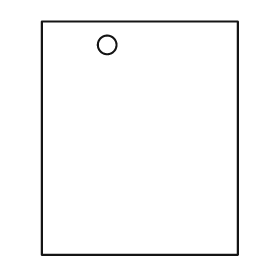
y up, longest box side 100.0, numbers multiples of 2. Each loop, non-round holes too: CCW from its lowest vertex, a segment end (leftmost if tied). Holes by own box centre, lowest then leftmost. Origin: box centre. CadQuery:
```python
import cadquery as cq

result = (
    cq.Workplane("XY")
    .moveTo(-42.0, -50.0)
    .lineTo(42.0, -50.0)
    .lineTo(42.0, 50.0)
    .lineTo(-42.0, 50.0)
    .close()
    .moveTo(-14.0, 40.0)
    .circle(4.0)
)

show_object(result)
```